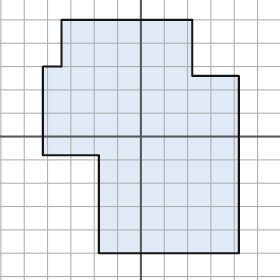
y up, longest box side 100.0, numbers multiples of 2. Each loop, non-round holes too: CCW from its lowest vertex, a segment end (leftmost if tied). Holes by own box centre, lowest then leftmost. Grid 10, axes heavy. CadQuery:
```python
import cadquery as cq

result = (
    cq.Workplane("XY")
    .moveTo(-18.0, -50.0)
    .lineTo(42.0, -50.0)
    .lineTo(42.0, 26.0)
    .lineTo(22.0, 26.0)
    .lineTo(22.0, 50.0)
    .lineTo(-34.0, 50.0)
    .lineTo(-34.0, 30.0)
    .lineTo(-42.0, 30.0)
    .lineTo(-42.0, -8.0)
    .lineTo(-18.0, -8.0)
    .close()
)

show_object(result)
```